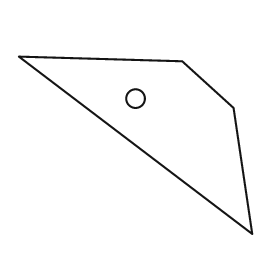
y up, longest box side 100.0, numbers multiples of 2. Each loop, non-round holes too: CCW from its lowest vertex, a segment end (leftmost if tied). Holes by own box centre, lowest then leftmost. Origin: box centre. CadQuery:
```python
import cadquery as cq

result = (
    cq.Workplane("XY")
    .moveTo(50.0, -38.0)
    .lineTo(42.0, 16.0)
    .lineTo(20.0, 36.0)
    .lineTo(-50.0, 38.0)
    .close()
    .moveTo(0.0, 20.0)
    .circle(4.0)
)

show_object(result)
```